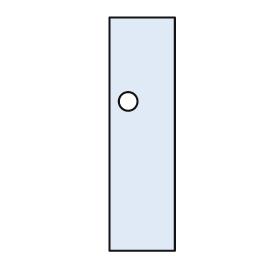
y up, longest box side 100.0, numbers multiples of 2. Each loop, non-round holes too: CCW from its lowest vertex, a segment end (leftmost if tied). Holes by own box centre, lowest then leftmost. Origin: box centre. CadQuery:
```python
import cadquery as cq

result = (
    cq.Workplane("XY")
    .moveTo(-14.0, -50.0)
    .lineTo(14.0, -50.0)
    .lineTo(14.0, 50.0)
    .lineTo(-14.0, 50.0)
    .close()
    .moveTo(-6.0, 14.0)
    .circle(4.0)
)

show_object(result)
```